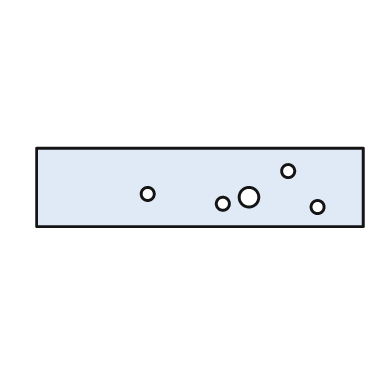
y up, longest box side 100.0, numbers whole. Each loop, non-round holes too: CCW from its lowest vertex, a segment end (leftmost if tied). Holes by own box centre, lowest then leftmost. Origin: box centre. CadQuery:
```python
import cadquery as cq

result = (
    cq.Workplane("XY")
    .moveTo(-50.0, -12.0)
    .lineTo(50.0, -12.0)
    .lineTo(50.0, 12.0)
    .lineTo(-50.0, 12.0)
    .close()
    .moveTo(36.0, -6.0)
    .circle(2.0)
    .moveTo(7.0, -5.0)
    .circle(2.0)
    .moveTo(15.0, -3.0)
    .circle(3.0)
    .moveTo(-16.0, -2.0)
    .circle(2.0)
    .moveTo(27.0, 5.0)
    .circle(2.0)
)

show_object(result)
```